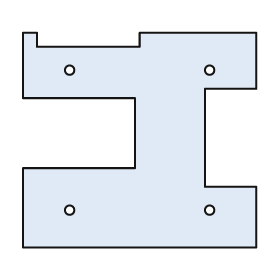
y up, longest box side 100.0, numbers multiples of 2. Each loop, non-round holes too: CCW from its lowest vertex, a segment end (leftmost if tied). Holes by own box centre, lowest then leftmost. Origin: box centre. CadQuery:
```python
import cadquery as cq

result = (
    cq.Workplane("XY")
    .moveTo(-50.0, -46.0)
    .lineTo(50.0, -46.0)
    .lineTo(50.0, -20.0)
    .lineTo(28.0, -20.0)
    .lineTo(28.0, 22.0)
    .lineTo(50.0, 22.0)
    .lineTo(50.0, 46.0)
    .lineTo(0.0, 46.0)
    .lineTo(0.0, 40.0)
    .lineTo(-44.0, 40.0)
    .lineTo(-44.0, 46.0)
    .lineTo(-50.0, 46.0)
    .lineTo(-50.0, 18.0)
    .lineTo(-2.0, 18.0)
    .lineTo(-2.0, -12.0)
    .lineTo(-50.0, -12.0)
    .close()
    .moveTo(-30.0, -30.0)
    .circle(2.0)
    .moveTo(30.0, -30.0)
    .circle(2.0)
    .moveTo(-30.0, 30.0)
    .circle(2.0)
    .moveTo(30.0, 30.0)
    .circle(2.0)
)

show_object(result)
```